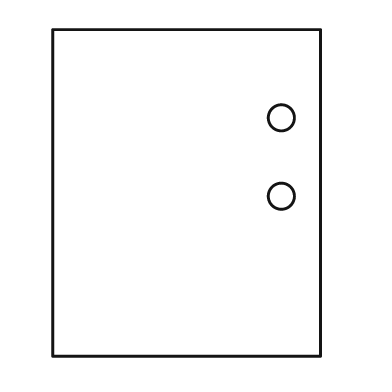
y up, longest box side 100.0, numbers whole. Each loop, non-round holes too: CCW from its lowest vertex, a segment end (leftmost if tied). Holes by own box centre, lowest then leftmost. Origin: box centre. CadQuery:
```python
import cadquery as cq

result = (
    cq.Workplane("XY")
    .moveTo(-41.0, -50.0)
    .lineTo(41.0, -50.0)
    .lineTo(41.0, 50.0)
    .lineTo(-41.0, 50.0)
    .close()
    .moveTo(29.0, -1.0)
    .circle(4.0)
    .moveTo(29.0, 23.0)
    .circle(4.0)
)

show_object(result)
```